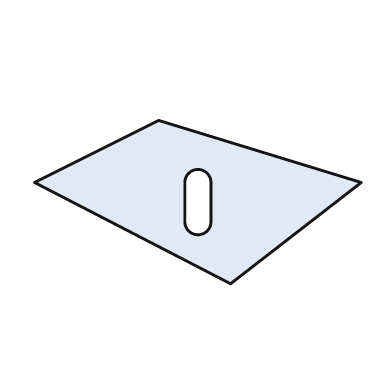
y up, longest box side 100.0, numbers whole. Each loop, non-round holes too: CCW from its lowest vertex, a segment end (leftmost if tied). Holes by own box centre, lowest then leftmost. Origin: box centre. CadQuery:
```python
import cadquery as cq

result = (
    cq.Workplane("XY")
    .moveTo(10.0, -25.0)
    .lineTo(50.0, 6.0)
    .lineTo(-12.0, 25.0)
    .lineTo(-50.0, 6.0)
    .close()
    .moveTo(-4.0, -6.0)
    .threePointArc((0.0, -10.0), (4.0, -6.0))
    .lineTo(4.0, 6.0)
    .threePointArc((0.0, 10.0), (-4.0, 6.0))
    .close()
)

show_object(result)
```